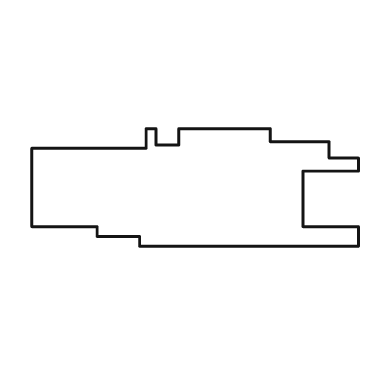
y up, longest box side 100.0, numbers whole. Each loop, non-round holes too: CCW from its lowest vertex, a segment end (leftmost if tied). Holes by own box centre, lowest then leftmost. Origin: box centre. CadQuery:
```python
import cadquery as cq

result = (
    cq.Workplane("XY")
    .moveTo(-17.0, -18.0)
    .lineTo(50.0, -18.0)
    .lineTo(50.0, -12.0)
    .lineTo(33.0, -12.0)
    .lineTo(33.0, 5.0)
    .lineTo(50.0, 5.0)
    .lineTo(50.0, 9.0)
    .lineTo(41.0, 9.0)
    .lineTo(41.0, 14.0)
    .lineTo(23.0, 14.0)
    .lineTo(23.0, 18.0)
    .lineTo(-5.0, 18.0)
    .lineTo(-5.0, 13.0)
    .lineTo(-12.0, 13.0)
    .lineTo(-12.0, 18.0)
    .lineTo(-15.0, 18.0)
    .lineTo(-15.0, 12.0)
    .lineTo(-50.0, 12.0)
    .lineTo(-50.0, -12.0)
    .lineTo(-30.0, -12.0)
    .lineTo(-30.0, -15.0)
    .lineTo(-17.0, -15.0)
    .close()
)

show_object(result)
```